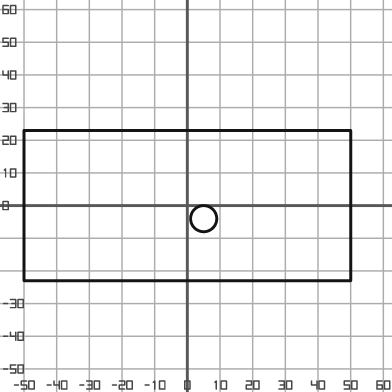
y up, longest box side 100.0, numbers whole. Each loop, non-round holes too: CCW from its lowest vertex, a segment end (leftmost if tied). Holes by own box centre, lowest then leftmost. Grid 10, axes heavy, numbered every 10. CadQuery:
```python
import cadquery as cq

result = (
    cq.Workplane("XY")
    .moveTo(-50.0, -23.0)
    .lineTo(50.0, -23.0)
    .lineTo(50.0, 23.0)
    .lineTo(-50.0, 23.0)
    .close()
    .moveTo(5.0, -4.0)
    .circle(4.0)
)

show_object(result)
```